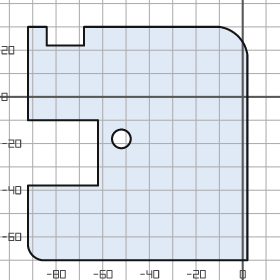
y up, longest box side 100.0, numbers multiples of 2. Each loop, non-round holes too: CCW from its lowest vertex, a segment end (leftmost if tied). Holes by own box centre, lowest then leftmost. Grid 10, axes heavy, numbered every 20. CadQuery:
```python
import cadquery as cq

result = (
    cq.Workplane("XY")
    .moveTo(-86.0, -70.0)
    .lineTo(2.0, -70.0)
    .lineTo(2.0, 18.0)
    .threePointArc((-2.0, 26.0), (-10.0, 30.0))
    .lineTo(-68.0, 30.0)
    .lineTo(-68.0, 22.0)
    .lineTo(-84.0, 22.0)
    .lineTo(-84.0, 30.0)
    .lineTo(-92.0, 30.0)
    .lineTo(-92.0, -10.0)
    .lineTo(-62.0, -10.0)
    .lineTo(-62.0, -38.0)
    .lineTo(-92.0, -38.0)
    .lineTo(-92.0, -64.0)
    .threePointArc((-90.0, -68.0), (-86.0, -70.0))
    .close()
    .moveTo(-52.0, -18.0)
    .circle(4.0)
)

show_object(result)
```